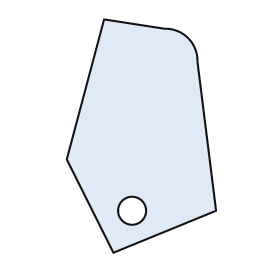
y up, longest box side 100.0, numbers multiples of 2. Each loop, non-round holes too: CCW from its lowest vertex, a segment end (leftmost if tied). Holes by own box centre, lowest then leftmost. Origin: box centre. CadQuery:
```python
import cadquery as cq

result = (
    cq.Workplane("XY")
    .moveTo(-12.0, -50.0)
    .lineTo(32.0, -32.0)
    .lineTo(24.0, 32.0)
    .threePointArc((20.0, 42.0), (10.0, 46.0))
    .lineTo(-16.0, 50.0)
    .lineTo(-32.0, -10.0)
    .close()
    .moveTo(-4.0, -32.0)
    .circle(6.0)
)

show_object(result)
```